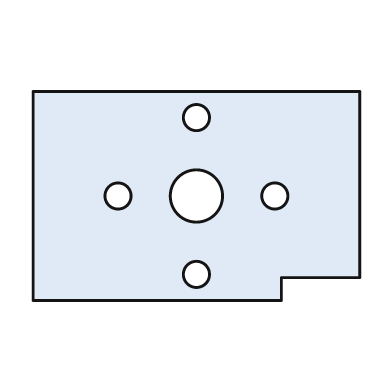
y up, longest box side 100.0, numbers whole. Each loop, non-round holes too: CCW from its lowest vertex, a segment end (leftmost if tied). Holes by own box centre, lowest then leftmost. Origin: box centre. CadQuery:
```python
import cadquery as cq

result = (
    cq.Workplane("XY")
    .moveTo(-50.0, -32.0)
    .lineTo(26.0, -32.0)
    .lineTo(26.0, -25.0)
    .lineTo(50.0, -25.0)
    .lineTo(50.0, 32.0)
    .lineTo(-50.0, 32.0)
    .close()
    .moveTo(0.0, -24.0)
    .circle(4.0)
    .moveTo(-24.0, 0.0)
    .circle(4.0)
    .moveTo(0.0, 0.0)
    .circle(8.0)
    .moveTo(24.0, 0.0)
    .circle(4.0)
    .moveTo(0.0, 24.0)
    .circle(4.0)
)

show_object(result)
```